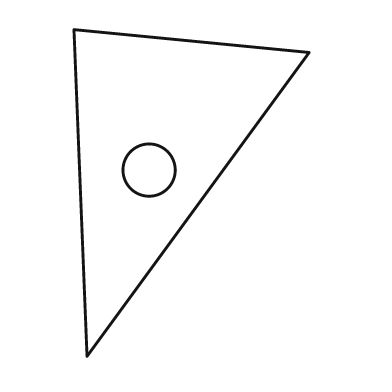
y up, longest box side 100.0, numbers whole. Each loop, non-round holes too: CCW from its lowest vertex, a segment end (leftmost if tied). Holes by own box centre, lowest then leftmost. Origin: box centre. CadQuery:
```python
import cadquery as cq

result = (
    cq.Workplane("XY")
    .moveTo(-32.0, -50.0)
    .lineTo(36.0, 43.0)
    .lineTo(-36.0, 50.0)
    .close()
    .moveTo(-13.0, 7.0)
    .circle(8.0)
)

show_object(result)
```